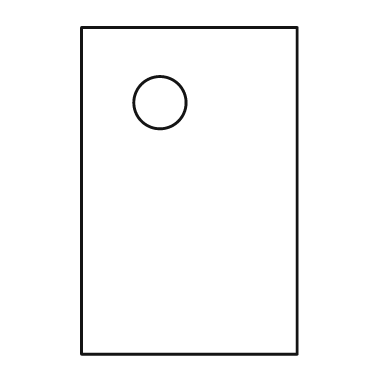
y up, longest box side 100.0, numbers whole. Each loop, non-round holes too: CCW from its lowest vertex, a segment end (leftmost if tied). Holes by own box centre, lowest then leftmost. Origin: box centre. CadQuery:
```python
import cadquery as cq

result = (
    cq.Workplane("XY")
    .moveTo(-33.0, -50.0)
    .lineTo(33.0, -50.0)
    .lineTo(33.0, 50.0)
    .lineTo(-33.0, 50.0)
    .close()
    .moveTo(-9.0, 27.0)
    .circle(8.0)
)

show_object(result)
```